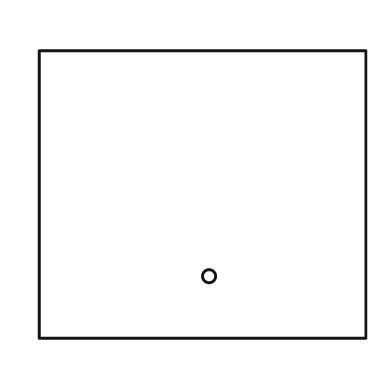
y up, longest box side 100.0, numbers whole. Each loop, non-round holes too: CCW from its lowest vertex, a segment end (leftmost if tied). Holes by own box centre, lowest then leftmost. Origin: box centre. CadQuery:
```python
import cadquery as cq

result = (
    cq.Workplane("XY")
    .moveTo(-50.0, -44.0)
    .lineTo(50.0, -44.0)
    .lineTo(50.0, 44.0)
    .lineTo(-50.0, 44.0)
    .close()
    .moveTo(2.0, -25.0)
    .circle(2.0)
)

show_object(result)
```